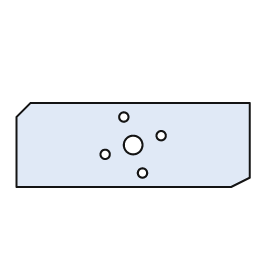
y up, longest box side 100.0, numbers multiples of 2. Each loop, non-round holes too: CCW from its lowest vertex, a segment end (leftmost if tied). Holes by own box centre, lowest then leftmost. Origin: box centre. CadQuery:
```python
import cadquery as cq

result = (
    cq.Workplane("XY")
    .moveTo(-50.0, -18.0)
    .lineTo(42.0, -18.0)
    .lineTo(50.0, -14.0)
    .lineTo(50.0, 18.0)
    .lineTo(-44.0, 18.0)
    .lineTo(-50.0, 12.0)
    .close()
    .moveTo(4.0, -12.0)
    .circle(2.0)
    .moveTo(-12.0, -4.0)
    .circle(2.0)
    .moveTo(0.0, 0.0)
    .circle(4.0)
    .moveTo(12.0, 4.0)
    .circle(2.0)
    .moveTo(-4.0, 12.0)
    .circle(2.0)
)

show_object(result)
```